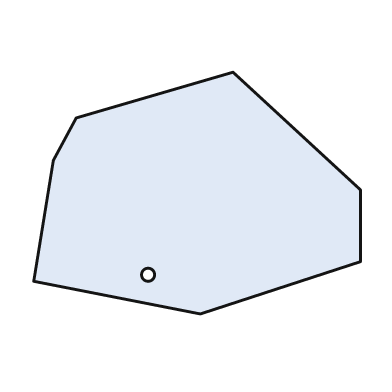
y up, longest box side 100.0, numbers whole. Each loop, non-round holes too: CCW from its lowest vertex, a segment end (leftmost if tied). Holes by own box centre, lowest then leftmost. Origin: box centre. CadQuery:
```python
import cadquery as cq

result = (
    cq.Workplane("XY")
    .moveTo(1.0, -37.0)
    .lineTo(50.0, -21.0)
    .lineTo(50.0, 1.0)
    .lineTo(11.0, 37.0)
    .lineTo(-37.0, 23.0)
    .lineTo(-44.0, 10.0)
    .lineTo(-50.0, -27.0)
    .close()
    .moveTo(-15.0, -25.0)
    .circle(2.0)
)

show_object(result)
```